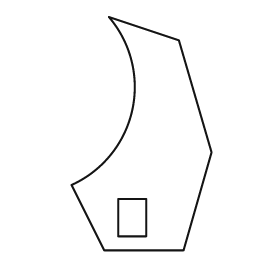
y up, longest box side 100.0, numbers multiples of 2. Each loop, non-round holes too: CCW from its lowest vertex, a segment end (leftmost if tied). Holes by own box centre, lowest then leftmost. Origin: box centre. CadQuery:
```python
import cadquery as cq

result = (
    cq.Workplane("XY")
    .moveTo(-16.0, -50.0)
    .lineTo(18.0, -50.0)
    .lineTo(30.0, -8.0)
    .lineTo(16.0, 40.0)
    .lineTo(-14.0, 50.0)
    .threePointArc((-4.0, 10.0), (-30.0, -22.0))
    .close()
    .moveTo(-10.0, -44.0)
    .lineTo(2.0, -44.0)
    .lineTo(2.0, -28.0)
    .lineTo(-10.0, -28.0)
    .close()
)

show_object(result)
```